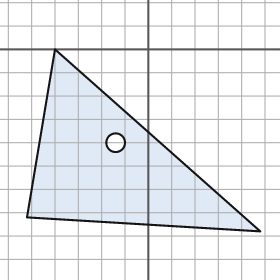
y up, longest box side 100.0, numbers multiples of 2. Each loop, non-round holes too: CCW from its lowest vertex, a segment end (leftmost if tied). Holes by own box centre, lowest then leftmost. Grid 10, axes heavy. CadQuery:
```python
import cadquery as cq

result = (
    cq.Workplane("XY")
    .moveTo(48.0, -78.0)
    .lineTo(-40.0, 0.0)
    .lineTo(-52.0, -72.0)
    .close()
    .moveTo(-14.0, -40.0)
    .circle(4.0)
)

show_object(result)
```